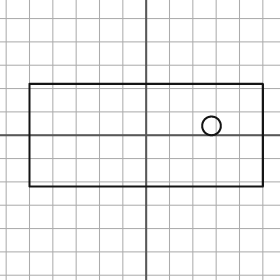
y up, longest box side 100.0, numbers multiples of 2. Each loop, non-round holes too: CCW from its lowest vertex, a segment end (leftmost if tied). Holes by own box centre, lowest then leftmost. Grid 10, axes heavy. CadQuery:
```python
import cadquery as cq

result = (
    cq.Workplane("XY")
    .moveTo(-50.0, -22.0)
    .lineTo(50.0, -22.0)
    .lineTo(50.0, 22.0)
    .lineTo(-50.0, 22.0)
    .close()
    .moveTo(28.0, 4.0)
    .circle(4.0)
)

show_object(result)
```